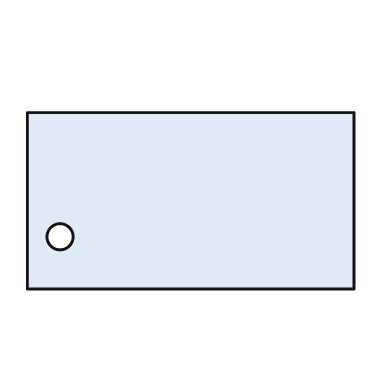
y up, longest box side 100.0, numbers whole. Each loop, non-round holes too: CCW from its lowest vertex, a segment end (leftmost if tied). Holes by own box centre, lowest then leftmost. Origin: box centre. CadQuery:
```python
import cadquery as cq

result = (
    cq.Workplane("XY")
    .moveTo(-50.0, -27.0)
    .lineTo(50.0, -27.0)
    .lineTo(50.0, 27.0)
    .lineTo(-50.0, 27.0)
    .close()
    .moveTo(-40.0, -11.0)
    .circle(4.0)
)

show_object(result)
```